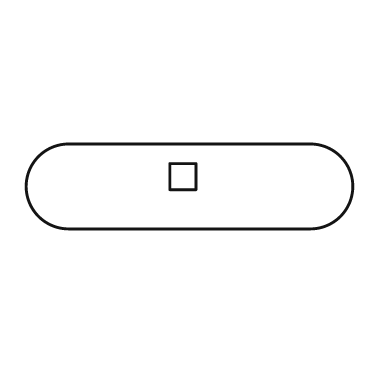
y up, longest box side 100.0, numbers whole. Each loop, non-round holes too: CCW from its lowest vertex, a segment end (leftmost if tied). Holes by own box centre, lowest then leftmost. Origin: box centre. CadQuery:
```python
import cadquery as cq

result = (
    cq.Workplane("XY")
    .moveTo(-37.0, -13.0)
    .lineTo(37.0, -13.0)
    .threePointArc((50.0, 0.0), (37.0, 13.0))
    .lineTo(-37.0, 13.0)
    .threePointArc((-50.0, 0.0), (-37.0, -13.0))
    .close()
    .moveTo(-6.0, -1.0)
    .lineTo(2.0, -1.0)
    .lineTo(2.0, 7.0)
    .lineTo(-6.0, 7.0)
    .close()
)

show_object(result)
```